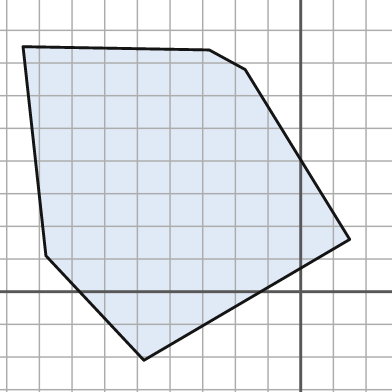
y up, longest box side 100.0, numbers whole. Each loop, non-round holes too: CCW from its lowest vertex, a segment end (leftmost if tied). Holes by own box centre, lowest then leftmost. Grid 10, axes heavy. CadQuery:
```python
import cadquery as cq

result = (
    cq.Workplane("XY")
    .moveTo(-48.0, -21.0)
    .lineTo(15.0, 16.0)
    .lineTo(-17.0, 68.0)
    .lineTo(-28.0, 74.0)
    .lineTo(-85.0, 75.0)
    .lineTo(-78.0, 11.0)
    .close()
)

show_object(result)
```